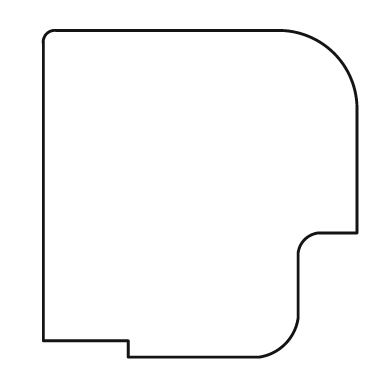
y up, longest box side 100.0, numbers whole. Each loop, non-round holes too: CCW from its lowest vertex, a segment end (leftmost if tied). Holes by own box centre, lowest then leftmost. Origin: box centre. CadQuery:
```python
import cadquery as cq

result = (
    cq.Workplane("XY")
    .moveTo(-22.0, -50.0)
    .lineTo(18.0, -50.0)
    .threePointArc((26.0, -46.0), (30.0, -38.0))
    .lineTo(30.0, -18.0)
    .threePointArc((32.0, -14.0), (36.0, -12.0))
    .lineTo(48.0, -12.0)
    .lineTo(48.0, 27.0)
    .threePointArc((41.0, 43.0), (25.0, 50.0))
    .lineTo(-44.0, 50.0)
    .threePointArc((-47.0, 49.0), (-48.0, 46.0))
    .lineTo(-48.0, -45.0)
    .lineTo(-22.0, -45.0)
    .close()
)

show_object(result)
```